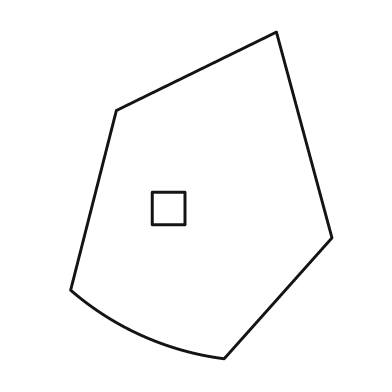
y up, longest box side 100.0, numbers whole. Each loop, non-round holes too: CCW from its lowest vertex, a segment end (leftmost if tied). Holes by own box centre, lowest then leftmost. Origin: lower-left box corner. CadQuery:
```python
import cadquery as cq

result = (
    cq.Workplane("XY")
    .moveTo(47.0, 0.0)
    .lineTo(80.0, 37.0)
    .lineTo(63.0, 100.0)
    .lineTo(14.0, 76.0)
    .lineTo(0.0, 21.0)
    .threePointArc((22.0, 7.0), (47.0, 0.0))
    .close()
    .moveTo(25.0, 41.0)
    .lineTo(35.0, 41.0)
    .lineTo(35.0, 51.0)
    .lineTo(25.0, 51.0)
    .close()
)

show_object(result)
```